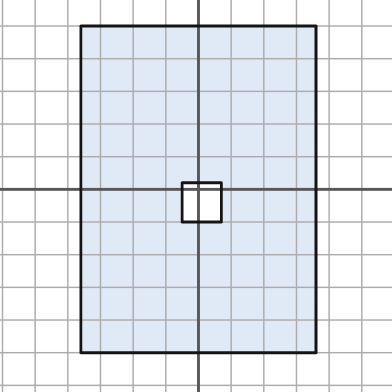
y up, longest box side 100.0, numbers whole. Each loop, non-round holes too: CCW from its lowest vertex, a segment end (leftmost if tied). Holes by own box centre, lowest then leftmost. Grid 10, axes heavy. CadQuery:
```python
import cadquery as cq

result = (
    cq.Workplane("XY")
    .moveTo(-36.0, -50.0)
    .lineTo(36.0, -50.0)
    .lineTo(36.0, 50.0)
    .lineTo(-36.0, 50.0)
    .close()
    .moveTo(-5.0, -10.0)
    .lineTo(7.0, -10.0)
    .lineTo(7.0, 2.0)
    .lineTo(-5.0, 2.0)
    .close()
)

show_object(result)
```